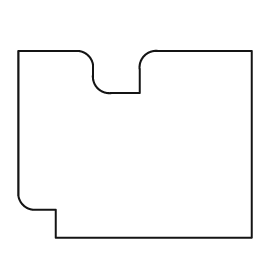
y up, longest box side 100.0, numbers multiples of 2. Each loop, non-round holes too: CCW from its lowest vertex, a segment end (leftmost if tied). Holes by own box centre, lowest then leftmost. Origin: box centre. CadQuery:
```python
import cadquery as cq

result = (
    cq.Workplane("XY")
    .moveTo(-34.0, -40.0)
    .lineTo(50.0, -40.0)
    .lineTo(50.0, 40.0)
    .lineTo(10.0, 40.0)
    .threePointArc((4.0, 38.0), (2.0, 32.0))
    .lineTo(2.0, 22.0)
    .lineTo(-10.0, 22.0)
    .threePointArc((-16.0, 24.0), (-18.0, 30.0))
    .lineTo(-18.0, 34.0)
    .threePointArc((-20.0, 38.0), (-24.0, 40.0))
    .lineTo(-50.0, 40.0)
    .lineTo(-50.0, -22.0)
    .threePointArc((-48.0, -26.0), (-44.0, -28.0))
    .lineTo(-34.0, -28.0)
    .close()
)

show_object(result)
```